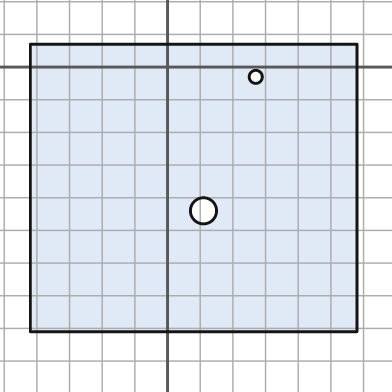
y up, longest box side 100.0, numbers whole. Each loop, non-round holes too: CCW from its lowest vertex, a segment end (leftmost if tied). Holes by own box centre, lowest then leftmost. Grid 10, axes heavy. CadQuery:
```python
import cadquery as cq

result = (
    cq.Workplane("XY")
    .moveTo(-42.0, -81.0)
    .lineTo(58.0, -81.0)
    .lineTo(58.0, 7.0)
    .lineTo(-42.0, 7.0)
    .close()
    .moveTo(11.0, -44.0)
    .circle(4.0)
    .moveTo(27.0, -3.0)
    .circle(2.0)
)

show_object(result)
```